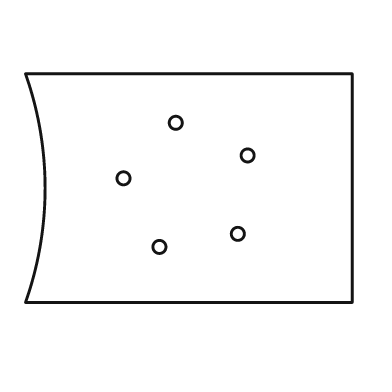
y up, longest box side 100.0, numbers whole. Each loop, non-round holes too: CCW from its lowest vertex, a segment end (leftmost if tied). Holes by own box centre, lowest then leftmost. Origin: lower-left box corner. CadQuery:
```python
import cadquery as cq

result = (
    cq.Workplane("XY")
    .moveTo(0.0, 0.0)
    .lineTo(100.0, 0.0)
    .lineTo(100.0, 70.0)
    .lineTo(0.0, 70.0)
    .threePointArc((6.0, 35.0), (0.0, 0.0))
    .close()
    .moveTo(41.0, 17.0)
    .circle(2.0)
    .moveTo(65.0, 21.0)
    .circle(2.0)
    .moveTo(30.0, 38.0)
    .circle(2.0)
    .moveTo(68.0, 45.0)
    .circle(2.0)
    .moveTo(46.0, 55.0)
    .circle(2.0)
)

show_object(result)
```